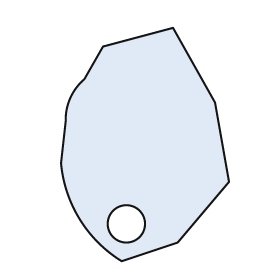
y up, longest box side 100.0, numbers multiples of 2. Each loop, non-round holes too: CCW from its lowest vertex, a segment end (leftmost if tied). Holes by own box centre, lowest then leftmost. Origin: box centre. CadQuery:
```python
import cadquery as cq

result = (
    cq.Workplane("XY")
    .moveTo(-10.0, -50.0)
    .lineTo(14.0, -42.0)
    .lineTo(36.0, -16.0)
    .lineTo(30.0, 18.0)
    .lineTo(12.0, 50.0)
    .lineTo(-18.0, 42.0)
    .lineTo(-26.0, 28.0)
    .threePointArc((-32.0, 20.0), (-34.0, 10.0))
    .lineTo(-36.0, -8.0)
    .threePointArc((-28.0, -32.0), (-10.0, -50.0))
    .close()
    .moveTo(-8.0, -34.0)
    .circle(8.0)
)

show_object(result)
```